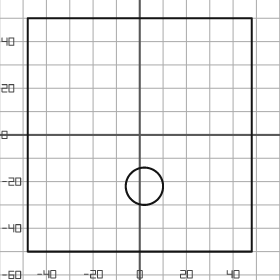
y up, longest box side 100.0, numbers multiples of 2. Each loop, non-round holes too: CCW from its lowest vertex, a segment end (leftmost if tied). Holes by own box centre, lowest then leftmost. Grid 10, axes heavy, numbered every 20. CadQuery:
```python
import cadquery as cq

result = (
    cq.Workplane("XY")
    .moveTo(-48.0, -50.0)
    .lineTo(48.0, -50.0)
    .lineTo(48.0, 50.0)
    .lineTo(-48.0, 50.0)
    .close()
    .moveTo(2.0, -22.0)
    .circle(8.0)
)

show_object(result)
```